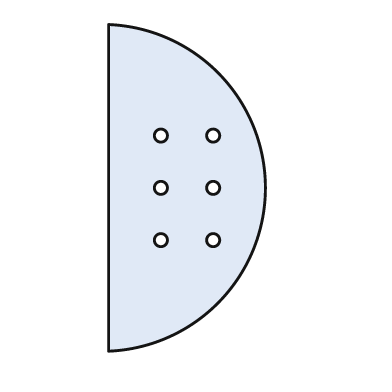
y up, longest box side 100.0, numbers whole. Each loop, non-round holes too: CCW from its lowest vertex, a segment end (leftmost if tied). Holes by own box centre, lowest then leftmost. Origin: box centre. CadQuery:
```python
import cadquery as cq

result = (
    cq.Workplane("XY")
    .moveTo(-24.0, -50.0)
    .threePointArc((24.0, 0.0), (-24.0, 50.0))
    .close()
    .moveTo(-8.0, -16.0)
    .circle(2.0)
    .moveTo(8.0, -16.0)
    .circle(2.0)
    .moveTo(-8.0, 0.0)
    .circle(2.0)
    .moveTo(8.0, 0.0)
    .circle(2.0)
    .moveTo(-8.0, 16.0)
    .circle(2.0)
    .moveTo(8.0, 16.0)
    .circle(2.0)
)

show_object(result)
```